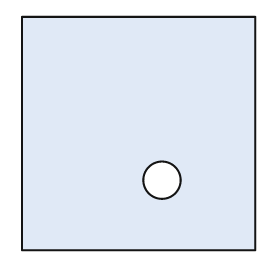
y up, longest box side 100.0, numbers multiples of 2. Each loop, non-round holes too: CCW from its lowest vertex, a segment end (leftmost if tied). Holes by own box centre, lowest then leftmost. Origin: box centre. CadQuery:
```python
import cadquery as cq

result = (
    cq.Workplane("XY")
    .moveTo(-50.0, -50.0)
    .lineTo(50.0, -50.0)
    .lineTo(50.0, 50.0)
    .lineTo(-50.0, 50.0)
    .close()
    .moveTo(10.0, -20.0)
    .circle(8.0)
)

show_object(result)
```